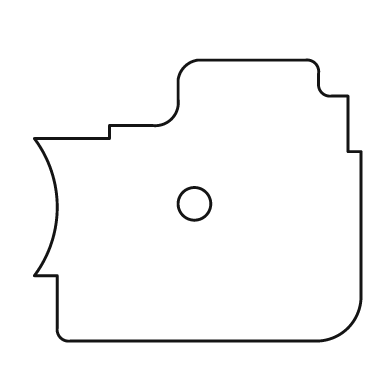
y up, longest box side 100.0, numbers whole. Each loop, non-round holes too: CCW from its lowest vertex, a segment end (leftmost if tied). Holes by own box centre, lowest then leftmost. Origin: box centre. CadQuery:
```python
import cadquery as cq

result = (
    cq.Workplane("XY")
    .moveTo(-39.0, -43.0)
    .lineTo(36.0, -43.0)
    .threePointArc((46.0, -39.0), (50.0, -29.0))
    .lineTo(50.0, 15.0)
    .lineTo(46.0, 15.0)
    .lineTo(46.0, 32.0)
    .lineTo(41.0, 32.0)
    .threePointArc((38.0, 33.0), (37.0, 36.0))
    .lineTo(37.0, 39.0)
    .threePointArc((36.0, 42.0), (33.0, 43.0))
    .lineTo(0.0, 43.0)
    .threePointArc((-4.0, 41.0), (-6.0, 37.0))
    .lineTo(-6.0, 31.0)
    .threePointArc((-8.0, 25.0), (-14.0, 23.0))
    .lineTo(-27.0, 23.0)
    .lineTo(-27.0, 19.0)
    .lineTo(-50.0, 19.0)
    .threePointArc((-43.0, -2.0), (-50.0, -23.0))
    .lineTo(-43.0, -23.0)
    .lineTo(-43.0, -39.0)
    .threePointArc((-42.0, -42.0), (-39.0, -43.0))
    .close()
    .moveTo(-1.0, -1.0)
    .circle(5.0)
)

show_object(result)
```